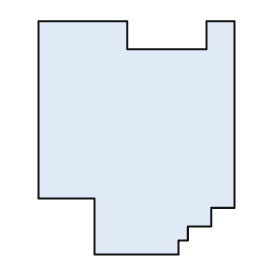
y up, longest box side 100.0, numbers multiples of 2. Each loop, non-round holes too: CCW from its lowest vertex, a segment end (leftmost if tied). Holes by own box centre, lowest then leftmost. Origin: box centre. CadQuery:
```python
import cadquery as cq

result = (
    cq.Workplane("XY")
    .moveTo(-18.0, -50.0)
    .lineTo(18.0, -50.0)
    .lineTo(18.0, -44.0)
    .lineTo(22.0, -44.0)
    .lineTo(22.0, -38.0)
    .lineTo(32.0, -38.0)
    .lineTo(32.0, -30.0)
    .lineTo(42.0, -30.0)
    .lineTo(42.0, 50.0)
    .lineTo(30.0, 50.0)
    .lineTo(30.0, 38.0)
    .lineTo(-4.0, 38.0)
    .lineTo(-4.0, 50.0)
    .lineTo(-42.0, 50.0)
    .lineTo(-42.0, -26.0)
    .lineTo(-18.0, -26.0)
    .close()
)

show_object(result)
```